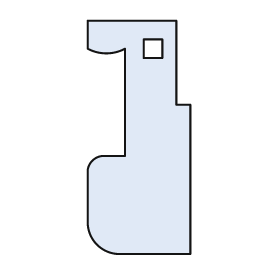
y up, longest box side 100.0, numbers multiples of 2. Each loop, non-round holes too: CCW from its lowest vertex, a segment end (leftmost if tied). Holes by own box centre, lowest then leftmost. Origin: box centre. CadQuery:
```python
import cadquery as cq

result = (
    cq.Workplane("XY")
    .moveTo(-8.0, -50.0)
    .lineTo(22.0, -50.0)
    .lineTo(22.0, 14.0)
    .lineTo(16.0, 14.0)
    .lineTo(16.0, 50.0)
    .lineTo(-22.0, 50.0)
    .lineTo(-22.0, 38.0)
    .threePointArc((-14.0, 36.0), (-6.0, 38.0))
    .lineTo(-6.0, -8.0)
    .lineTo(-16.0, -8.0)
    .threePointArc((-20.0, -10.0), (-22.0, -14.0))
    .lineTo(-22.0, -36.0)
    .threePointArc((-18.0, -46.0), (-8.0, -50.0))
    .close()
    .moveTo(2.0, 34.0)
    .lineTo(10.0, 34.0)
    .lineTo(10.0, 42.0)
    .lineTo(2.0, 42.0)
    .close()
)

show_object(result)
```